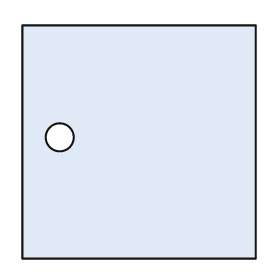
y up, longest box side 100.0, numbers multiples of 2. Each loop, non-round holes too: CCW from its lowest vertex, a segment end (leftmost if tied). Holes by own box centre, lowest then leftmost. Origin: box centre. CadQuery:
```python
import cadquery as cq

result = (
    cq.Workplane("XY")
    .moveTo(-50.0, -50.0)
    .lineTo(50.0, -50.0)
    .lineTo(50.0, 50.0)
    .lineTo(-50.0, 50.0)
    .close()
    .moveTo(-34.0, 2.0)
    .circle(6.0)
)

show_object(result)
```